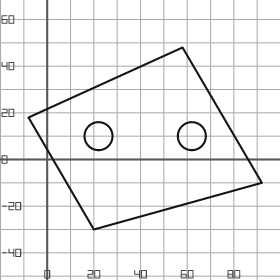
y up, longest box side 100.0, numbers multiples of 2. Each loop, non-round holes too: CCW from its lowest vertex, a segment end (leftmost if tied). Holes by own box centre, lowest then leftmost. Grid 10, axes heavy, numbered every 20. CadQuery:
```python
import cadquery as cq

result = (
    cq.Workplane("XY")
    .moveTo(20.0, -30.0)
    .lineTo(92.0, -10.0)
    .lineTo(58.0, 48.0)
    .lineTo(-8.0, 18.0)
    .close()
    .moveTo(22.0, 10.0)
    .circle(6.0)
    .moveTo(62.0, 10.0)
    .circle(6.0)
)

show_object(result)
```